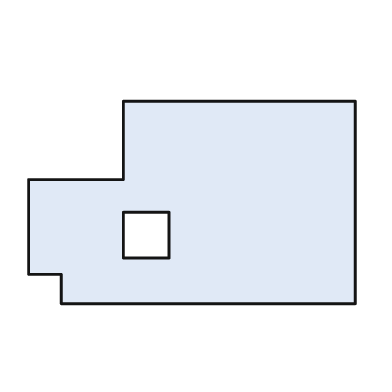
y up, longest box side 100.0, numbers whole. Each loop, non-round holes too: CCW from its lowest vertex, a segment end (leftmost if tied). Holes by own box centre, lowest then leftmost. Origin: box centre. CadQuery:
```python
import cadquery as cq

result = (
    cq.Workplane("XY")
    .moveTo(-40.0, -31.0)
    .lineTo(50.0, -31.0)
    .lineTo(50.0, 31.0)
    .lineTo(-21.0, 31.0)
    .lineTo(-21.0, 7.0)
    .lineTo(-50.0, 7.0)
    .lineTo(-50.0, -22.0)
    .lineTo(-40.0, -22.0)
    .close()
    .moveTo(-21.0, -17.0)
    .lineTo(-7.0, -17.0)
    .lineTo(-7.0, -3.0)
    .lineTo(-21.0, -3.0)
    .close()
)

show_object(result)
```